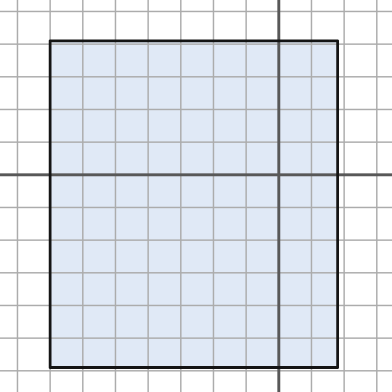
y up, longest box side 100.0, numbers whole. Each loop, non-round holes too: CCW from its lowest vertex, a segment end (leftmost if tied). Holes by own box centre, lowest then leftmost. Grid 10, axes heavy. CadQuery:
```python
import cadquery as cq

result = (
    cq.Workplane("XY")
    .moveTo(-70.0, -59.0)
    .lineTo(18.0, -59.0)
    .lineTo(18.0, 41.0)
    .lineTo(-70.0, 41.0)
    .close()
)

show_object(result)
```